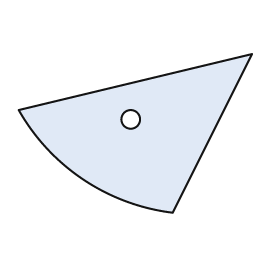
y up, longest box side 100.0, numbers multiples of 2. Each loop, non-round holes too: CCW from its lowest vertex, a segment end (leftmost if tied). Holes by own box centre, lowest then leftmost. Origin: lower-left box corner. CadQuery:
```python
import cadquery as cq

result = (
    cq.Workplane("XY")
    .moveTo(66.0, 0.0)
    .lineTo(100.0, 68.0)
    .lineTo(0.0, 44.0)
    .threePointArc((28.0, 14.0), (66.0, 0.0))
    .close()
    .moveTo(48.0, 40.0)
    .circle(4.0)
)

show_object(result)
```